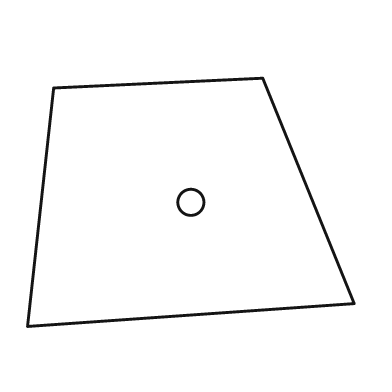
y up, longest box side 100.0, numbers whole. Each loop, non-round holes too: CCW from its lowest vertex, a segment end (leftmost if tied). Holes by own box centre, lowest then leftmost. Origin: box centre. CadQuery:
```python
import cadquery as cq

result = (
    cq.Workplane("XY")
    .moveTo(-50.0, -38.0)
    .lineTo(50.0, -31.0)
    .lineTo(22.0, 38.0)
    .lineTo(-42.0, 35.0)
    .close()
    .moveTo(0.0, 0.0)
    .circle(4.0)
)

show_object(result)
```